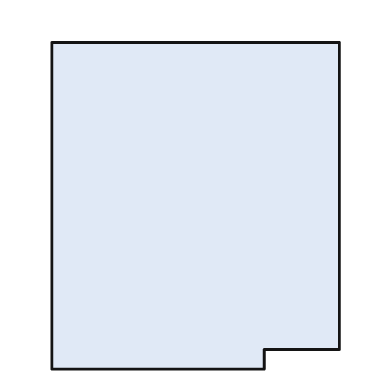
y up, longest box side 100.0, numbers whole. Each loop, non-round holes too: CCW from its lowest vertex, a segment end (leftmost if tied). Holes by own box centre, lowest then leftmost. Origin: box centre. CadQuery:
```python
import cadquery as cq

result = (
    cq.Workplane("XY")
    .moveTo(-44.0, -50.0)
    .lineTo(21.0, -50.0)
    .lineTo(21.0, -44.0)
    .lineTo(44.0, -44.0)
    .lineTo(44.0, 50.0)
    .lineTo(-44.0, 50.0)
    .close()
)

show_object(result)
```